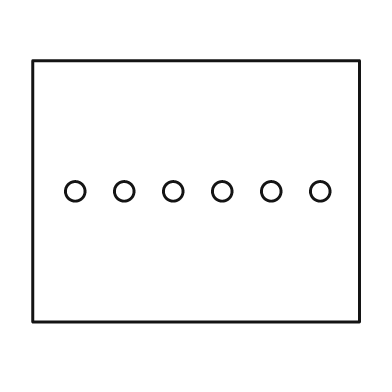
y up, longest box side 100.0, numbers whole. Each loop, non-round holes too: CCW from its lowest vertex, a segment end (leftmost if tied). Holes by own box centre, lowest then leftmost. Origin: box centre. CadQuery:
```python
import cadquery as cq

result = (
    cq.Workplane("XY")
    .moveTo(-50.0, -40.0)
    .lineTo(50.0, -40.0)
    .lineTo(50.0, 40.0)
    .lineTo(-50.0, 40.0)
    .close()
    .moveTo(-37.0, 0.0)
    .circle(3.0)
    .moveTo(-22.0, 0.0)
    .circle(3.0)
    .moveTo(-7.0, 0.0)
    .circle(3.0)
    .moveTo(8.0, 0.0)
    .circle(3.0)
    .moveTo(23.0, 0.0)
    .circle(3.0)
    .moveTo(38.0, 0.0)
    .circle(3.0)
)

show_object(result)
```